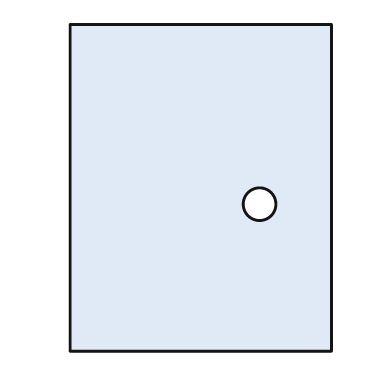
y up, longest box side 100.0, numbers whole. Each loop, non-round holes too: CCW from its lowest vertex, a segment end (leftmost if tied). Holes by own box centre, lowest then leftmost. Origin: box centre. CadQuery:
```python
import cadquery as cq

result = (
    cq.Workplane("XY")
    .moveTo(-40.0, -50.0)
    .lineTo(40.0, -50.0)
    .lineTo(40.0, 50.0)
    .lineTo(-40.0, 50.0)
    .close()
    .moveTo(18.0, -5.0)
    .circle(5.0)
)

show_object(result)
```